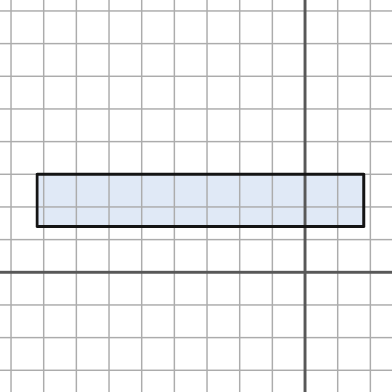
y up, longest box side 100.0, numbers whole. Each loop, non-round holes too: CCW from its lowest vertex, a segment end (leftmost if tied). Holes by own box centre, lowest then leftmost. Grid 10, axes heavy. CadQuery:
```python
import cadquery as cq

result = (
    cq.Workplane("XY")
    .moveTo(-82.0, 14.0)
    .lineTo(18.0, 14.0)
    .lineTo(18.0, 30.0)
    .lineTo(-82.0, 30.0)
    .close()
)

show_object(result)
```